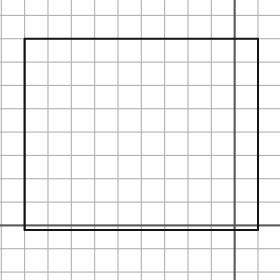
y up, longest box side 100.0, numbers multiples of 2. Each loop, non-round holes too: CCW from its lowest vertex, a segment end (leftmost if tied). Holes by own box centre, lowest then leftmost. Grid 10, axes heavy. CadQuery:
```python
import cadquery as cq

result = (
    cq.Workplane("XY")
    .moveTo(-90.0, -2.0)
    .lineTo(10.0, -2.0)
    .lineTo(10.0, 80.0)
    .lineTo(-90.0, 80.0)
    .close()
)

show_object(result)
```